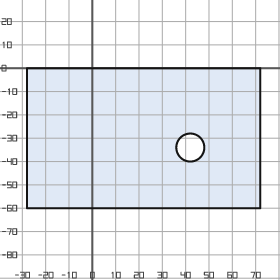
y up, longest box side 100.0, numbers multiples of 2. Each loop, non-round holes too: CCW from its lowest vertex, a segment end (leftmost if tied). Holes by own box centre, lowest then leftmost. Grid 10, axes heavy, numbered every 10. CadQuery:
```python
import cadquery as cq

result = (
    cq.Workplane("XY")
    .moveTo(-28.0, -60.0)
    .lineTo(72.0, -60.0)
    .lineTo(72.0, 0.0)
    .lineTo(-28.0, 0.0)
    .close()
    .moveTo(42.0, -34.0)
    .circle(6.0)
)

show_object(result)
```